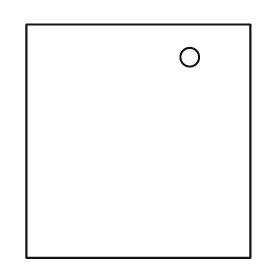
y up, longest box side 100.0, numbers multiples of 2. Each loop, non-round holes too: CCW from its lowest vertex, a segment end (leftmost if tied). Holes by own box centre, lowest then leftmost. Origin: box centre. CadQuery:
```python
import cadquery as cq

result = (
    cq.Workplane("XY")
    .moveTo(-48.0, -50.0)
    .lineTo(48.0, -50.0)
    .lineTo(48.0, 50.0)
    .lineTo(-48.0, 50.0)
    .close()
    .moveTo(22.0, 36.0)
    .circle(4.0)
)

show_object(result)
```